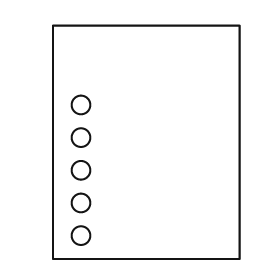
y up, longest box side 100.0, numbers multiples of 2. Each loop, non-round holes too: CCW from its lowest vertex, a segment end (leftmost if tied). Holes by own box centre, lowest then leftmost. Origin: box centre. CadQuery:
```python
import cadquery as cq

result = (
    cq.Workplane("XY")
    .moveTo(-40.0, -50.0)
    .lineTo(40.0, -50.0)
    .lineTo(40.0, 50.0)
    .lineTo(-40.0, 50.0)
    .close()
    .moveTo(-28.0, -40.0)
    .circle(4.0)
    .moveTo(-28.0, -26.0)
    .circle(4.0)
    .moveTo(-28.0, -12.0)
    .circle(4.0)
    .moveTo(-28.0, 2.0)
    .circle(4.0)
    .moveTo(-28.0, 16.0)
    .circle(4.0)
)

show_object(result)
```